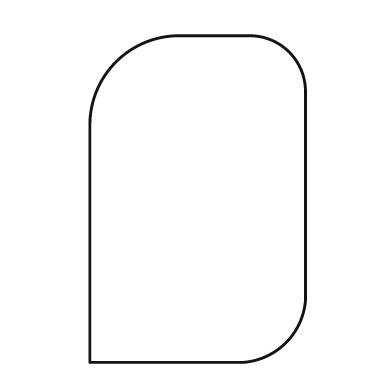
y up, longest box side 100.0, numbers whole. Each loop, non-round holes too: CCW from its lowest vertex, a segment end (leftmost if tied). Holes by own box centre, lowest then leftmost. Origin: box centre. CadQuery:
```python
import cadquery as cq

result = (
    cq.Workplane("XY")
    .moveTo(-33.0, -50.0)
    .lineTo(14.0, -50.0)
    .threePointArc((27.0, -44.0), (33.0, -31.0))
    .lineTo(33.0, 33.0)
    .threePointArc((28.0, 45.0), (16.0, 50.0))
    .lineTo(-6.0, 50.0)
    .threePointArc((-25.0, 42.0), (-33.0, 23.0))
    .close()
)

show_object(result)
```